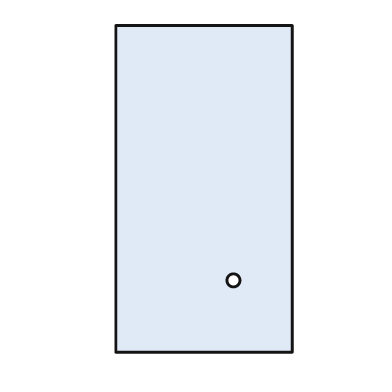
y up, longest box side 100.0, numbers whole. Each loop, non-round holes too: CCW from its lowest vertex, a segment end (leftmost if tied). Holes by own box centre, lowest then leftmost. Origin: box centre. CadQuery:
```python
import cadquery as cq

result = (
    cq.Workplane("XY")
    .moveTo(-27.0, -50.0)
    .lineTo(27.0, -50.0)
    .lineTo(27.0, 50.0)
    .lineTo(-27.0, 50.0)
    .close()
    .moveTo(9.0, -28.0)
    .circle(2.0)
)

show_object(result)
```